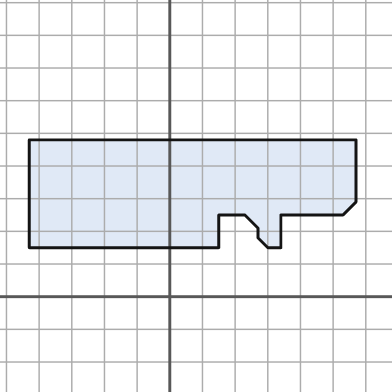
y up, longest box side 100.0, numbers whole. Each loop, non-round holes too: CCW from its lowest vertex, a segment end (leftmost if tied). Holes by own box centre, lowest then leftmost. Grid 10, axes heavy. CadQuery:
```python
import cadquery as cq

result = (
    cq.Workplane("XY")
    .moveTo(-43.0, 15.0)
    .lineTo(15.0, 15.0)
    .lineTo(15.0, 25.0)
    .lineTo(23.0, 25.0)
    .lineTo(27.0, 21.0)
    .lineTo(27.0, 18.0)
    .lineTo(30.0, 15.0)
    .lineTo(34.0, 15.0)
    .lineTo(34.0, 25.0)
    .lineTo(53.0, 25.0)
    .lineTo(57.0, 29.0)
    .lineTo(57.0, 48.0)
    .lineTo(-43.0, 48.0)
    .close()
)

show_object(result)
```